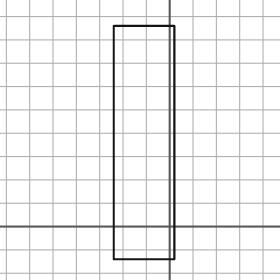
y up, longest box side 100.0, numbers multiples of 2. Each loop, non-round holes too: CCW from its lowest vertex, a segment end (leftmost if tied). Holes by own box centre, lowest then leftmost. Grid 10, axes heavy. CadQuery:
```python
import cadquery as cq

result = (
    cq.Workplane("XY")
    .moveTo(-24.0, -14.0)
    .lineTo(2.0, -14.0)
    .lineTo(2.0, 86.0)
    .lineTo(-24.0, 86.0)
    .close()
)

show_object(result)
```